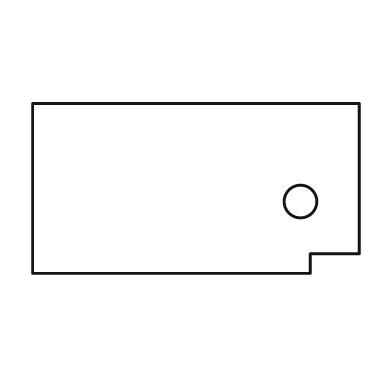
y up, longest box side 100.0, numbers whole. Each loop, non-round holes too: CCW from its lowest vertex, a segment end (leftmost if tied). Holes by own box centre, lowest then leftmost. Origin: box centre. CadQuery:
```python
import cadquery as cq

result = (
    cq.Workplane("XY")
    .moveTo(-50.0, -26.0)
    .lineTo(35.0, -26.0)
    .lineTo(35.0, -20.0)
    .lineTo(50.0, -20.0)
    .lineTo(50.0, 26.0)
    .lineTo(-50.0, 26.0)
    .close()
    .moveTo(32.0, -4.0)
    .circle(5.0)
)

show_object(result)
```